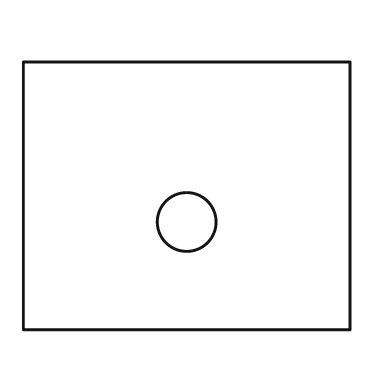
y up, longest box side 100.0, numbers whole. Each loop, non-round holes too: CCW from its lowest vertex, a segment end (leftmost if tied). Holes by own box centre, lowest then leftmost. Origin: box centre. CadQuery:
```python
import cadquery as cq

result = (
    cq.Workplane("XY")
    .moveTo(-50.0, -41.0)
    .lineTo(50.0, -41.0)
    .lineTo(50.0, 41.0)
    .lineTo(-50.0, 41.0)
    .close()
    .moveTo(0.0, -8.0)
    .circle(9.0)
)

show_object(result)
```